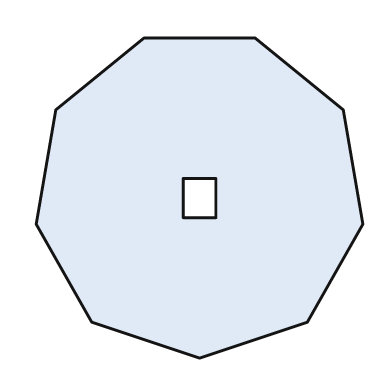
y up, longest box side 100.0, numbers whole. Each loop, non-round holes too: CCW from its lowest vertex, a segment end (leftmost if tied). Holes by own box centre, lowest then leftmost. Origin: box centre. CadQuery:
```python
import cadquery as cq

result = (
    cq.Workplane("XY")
    .moveTo(0.0, -49.0)
    .lineTo(33.0, -38.0)
    .lineTo(50.0, -8.0)
    .lineTo(44.0, 27.0)
    .lineTo(17.0, 49.0)
    .lineTo(-17.0, 49.0)
    .lineTo(-44.0, 27.0)
    .lineTo(-50.0, -8.0)
    .lineTo(-33.0, -38.0)
    .close()
    .moveTo(-5.0, -6.0)
    .lineTo(5.0, -6.0)
    .lineTo(5.0, 6.0)
    .lineTo(-5.0, 6.0)
    .close()
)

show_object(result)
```